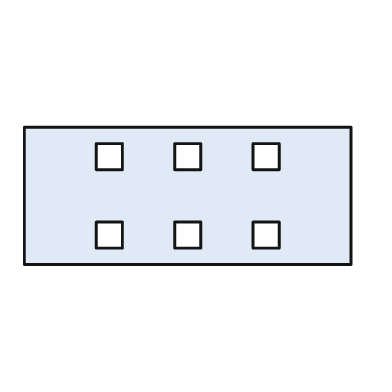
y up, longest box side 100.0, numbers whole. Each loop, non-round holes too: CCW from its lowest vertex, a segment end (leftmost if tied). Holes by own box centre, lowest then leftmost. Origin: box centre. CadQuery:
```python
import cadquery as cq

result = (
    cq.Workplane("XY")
    .moveTo(-50.0, -21.0)
    .lineTo(50.0, -21.0)
    .lineTo(50.0, 21.0)
    .lineTo(-50.0, 21.0)
    .close()
    .moveTo(-28.0, -16.0)
    .lineTo(-20.0, -16.0)
    .lineTo(-20.0, -8.0)
    .lineTo(-28.0, -8.0)
    .close()
    .moveTo(-4.0, -16.0)
    .lineTo(4.0, -16.0)
    .lineTo(4.0, -8.0)
    .lineTo(-4.0, -8.0)
    .close()
    .moveTo(20.0, -16.0)
    .lineTo(28.0, -16.0)
    .lineTo(28.0, -8.0)
    .lineTo(20.0, -8.0)
    .close()
    .moveTo(-28.0, 8.0)
    .lineTo(-20.0, 8.0)
    .lineTo(-20.0, 16.0)
    .lineTo(-28.0, 16.0)
    .close()
    .moveTo(-4.0, 8.0)
    .lineTo(4.0, 8.0)
    .lineTo(4.0, 16.0)
    .lineTo(-4.0, 16.0)
    .close()
    .moveTo(20.0, 8.0)
    .lineTo(28.0, 8.0)
    .lineTo(28.0, 16.0)
    .lineTo(20.0, 16.0)
    .close()
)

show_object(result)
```